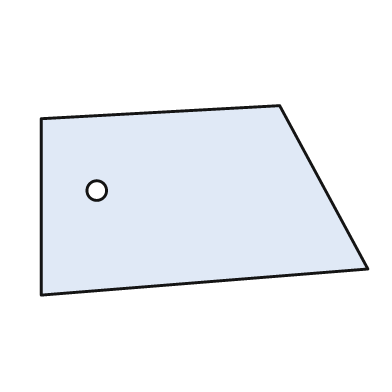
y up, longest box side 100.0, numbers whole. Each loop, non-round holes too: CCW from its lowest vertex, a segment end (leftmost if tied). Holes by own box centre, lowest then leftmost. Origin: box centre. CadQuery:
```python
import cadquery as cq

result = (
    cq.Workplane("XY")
    .moveTo(-50.0, -29.0)
    .lineTo(50.0, -21.0)
    .lineTo(23.0, 29.0)
    .lineTo(-50.0, 25.0)
    .close()
    .moveTo(-33.0, 3.0)
    .circle(3.0)
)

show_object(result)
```